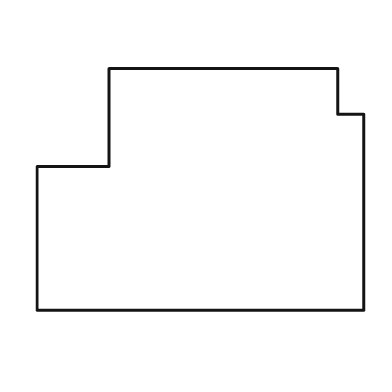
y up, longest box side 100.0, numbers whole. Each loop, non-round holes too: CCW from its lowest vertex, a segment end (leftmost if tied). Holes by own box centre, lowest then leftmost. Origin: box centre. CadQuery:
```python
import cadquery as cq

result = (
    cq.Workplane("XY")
    .moveTo(-50.0, -37.0)
    .lineTo(50.0, -37.0)
    .lineTo(50.0, 23.0)
    .lineTo(42.0, 23.0)
    .lineTo(42.0, 37.0)
    .lineTo(-28.0, 37.0)
    .lineTo(-28.0, 7.0)
    .lineTo(-50.0, 7.0)
    .close()
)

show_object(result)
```